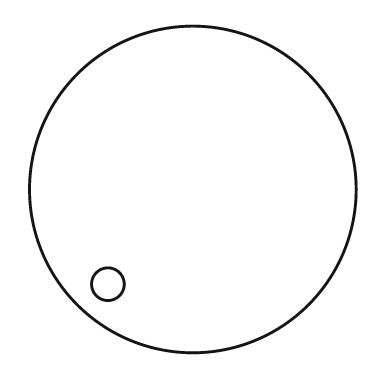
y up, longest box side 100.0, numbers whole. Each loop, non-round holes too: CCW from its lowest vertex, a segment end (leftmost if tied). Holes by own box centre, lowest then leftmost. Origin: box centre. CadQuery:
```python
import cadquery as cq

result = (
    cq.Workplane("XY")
    .moveTo(0.0, 0.0)
    .circle(50.0)
    .moveTo(-26.0, -29.0)
    .circle(5.0)
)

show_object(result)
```